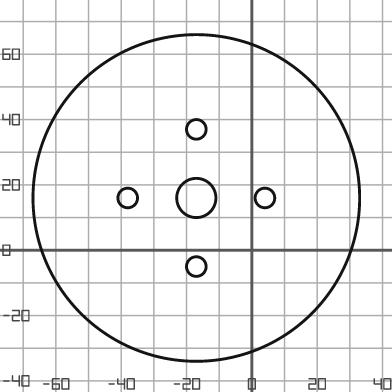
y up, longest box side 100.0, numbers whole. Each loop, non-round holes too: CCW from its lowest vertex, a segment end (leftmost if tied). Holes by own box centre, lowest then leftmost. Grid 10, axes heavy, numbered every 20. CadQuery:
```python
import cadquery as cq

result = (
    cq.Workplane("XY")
    .moveTo(-17.0, 16.0)
    .circle(50.0)
    .moveTo(-17.0, -5.0)
    .circle(3.0)
    .moveTo(-38.0, 16.0)
    .circle(3.0)
    .moveTo(-17.0, 16.0)
    .circle(6.0)
    .moveTo(4.0, 16.0)
    .circle(3.0)
    .moveTo(-17.0, 37.0)
    .circle(3.0)
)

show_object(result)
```